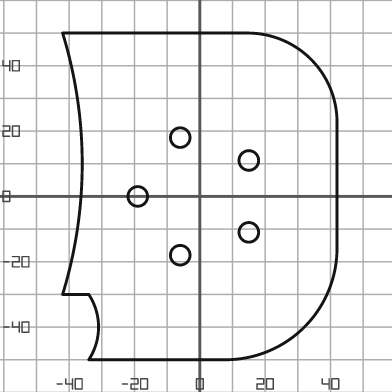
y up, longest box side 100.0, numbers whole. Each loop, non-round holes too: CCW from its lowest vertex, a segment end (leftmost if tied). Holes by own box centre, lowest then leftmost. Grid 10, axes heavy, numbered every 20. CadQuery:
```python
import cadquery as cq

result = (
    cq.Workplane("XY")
    .moveTo(-34.0, -50.0)
    .lineTo(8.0, -50.0)
    .threePointArc((32.0, -40.0), (42.0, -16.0))
    .lineTo(42.0, 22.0)
    .threePointArc((34.0, 42.0), (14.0, 50.0))
    .lineTo(-42.0, 50.0)
    .threePointArc((-36.0, 10.0), (-42.0, -30.0))
    .lineTo(-34.0, -30.0)
    .threePointArc((-31.0, -40.0), (-34.0, -50.0))
    .close()
    .moveTo(-6.0, -18.0)
    .circle(3.0)
    .moveTo(15.0, -11.0)
    .circle(3.0)
    .moveTo(-19.0, 0.0)
    .circle(3.0)
    .moveTo(15.0, 11.0)
    .circle(3.0)
    .moveTo(-6.0, 18.0)
    .circle(3.0)
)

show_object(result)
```